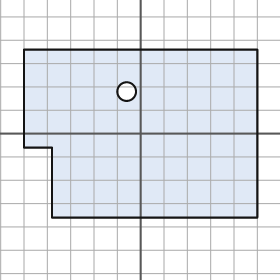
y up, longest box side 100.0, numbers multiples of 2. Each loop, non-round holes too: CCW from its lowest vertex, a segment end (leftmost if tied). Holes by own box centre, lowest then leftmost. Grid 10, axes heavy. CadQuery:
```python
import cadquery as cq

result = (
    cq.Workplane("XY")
    .moveTo(-38.0, -36.0)
    .lineTo(50.0, -36.0)
    .lineTo(50.0, 36.0)
    .lineTo(-50.0, 36.0)
    .lineTo(-50.0, -6.0)
    .lineTo(-38.0, -6.0)
    .close()
    .moveTo(-6.0, 18.0)
    .circle(4.0)
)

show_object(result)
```